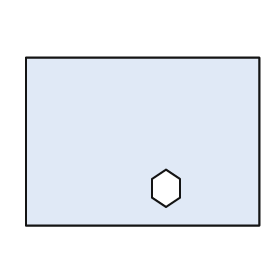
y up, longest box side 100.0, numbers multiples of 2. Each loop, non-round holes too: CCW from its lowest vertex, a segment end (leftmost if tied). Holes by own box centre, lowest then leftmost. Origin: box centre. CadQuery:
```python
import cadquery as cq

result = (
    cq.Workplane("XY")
    .moveTo(-50.0, -36.0)
    .lineTo(50.0, -36.0)
    .lineTo(50.0, 36.0)
    .lineTo(-50.0, 36.0)
    .close()
    .moveTo(10.0, -28.0)
    .lineTo(16.0, -24.0)
    .lineTo(16.0, -16.0)
    .lineTo(10.0, -12.0)
    .lineTo(4.0, -16.0)
    .lineTo(4.0, -24.0)
    .close()
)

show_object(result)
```